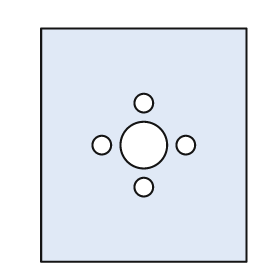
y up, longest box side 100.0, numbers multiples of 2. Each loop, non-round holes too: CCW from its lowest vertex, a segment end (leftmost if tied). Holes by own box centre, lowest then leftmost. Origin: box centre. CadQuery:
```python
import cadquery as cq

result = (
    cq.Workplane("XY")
    .moveTo(-44.0, -50.0)
    .lineTo(44.0, -50.0)
    .lineTo(44.0, 50.0)
    .lineTo(-44.0, 50.0)
    .close()
    .moveTo(0.0, -18.0)
    .circle(4.0)
    .moveTo(-18.0, 0.0)
    .circle(4.0)
    .moveTo(0.0, 0.0)
    .circle(10.0)
    .moveTo(18.0, 0.0)
    .circle(4.0)
    .moveTo(0.0, 18.0)
    .circle(4.0)
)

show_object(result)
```